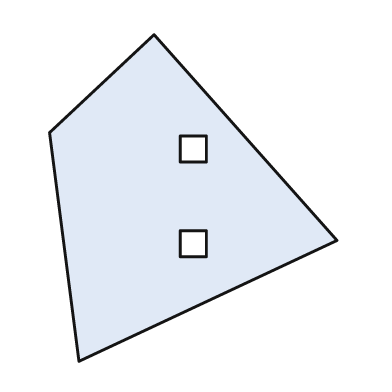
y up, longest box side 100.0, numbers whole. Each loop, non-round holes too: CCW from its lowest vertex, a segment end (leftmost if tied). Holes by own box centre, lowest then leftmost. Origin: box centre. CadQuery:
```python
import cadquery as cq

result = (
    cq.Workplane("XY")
    .moveTo(-35.0, -50.0)
    .lineTo(44.0, -13.0)
    .lineTo(-12.0, 50.0)
    .lineTo(-44.0, 20.0)
    .close()
    .moveTo(-4.0, -18.0)
    .lineTo(4.0, -18.0)
    .lineTo(4.0, -10.0)
    .lineTo(-4.0, -10.0)
    .close()
    .moveTo(-4.0, 11.0)
    .lineTo(4.0, 11.0)
    .lineTo(4.0, 19.0)
    .lineTo(-4.0, 19.0)
    .close()
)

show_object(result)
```